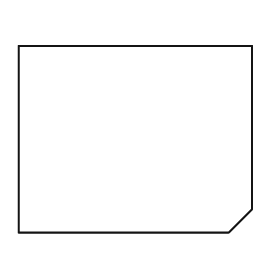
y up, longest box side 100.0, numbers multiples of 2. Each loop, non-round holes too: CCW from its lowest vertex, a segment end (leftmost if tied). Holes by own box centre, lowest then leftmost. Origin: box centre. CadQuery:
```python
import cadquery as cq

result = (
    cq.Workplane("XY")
    .moveTo(-50.0, -40.0)
    .lineTo(40.0, -40.0)
    .lineTo(50.0, -30.0)
    .lineTo(50.0, 40.0)
    .lineTo(-50.0, 40.0)
    .close()
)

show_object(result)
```